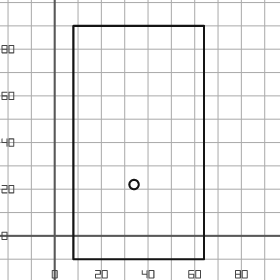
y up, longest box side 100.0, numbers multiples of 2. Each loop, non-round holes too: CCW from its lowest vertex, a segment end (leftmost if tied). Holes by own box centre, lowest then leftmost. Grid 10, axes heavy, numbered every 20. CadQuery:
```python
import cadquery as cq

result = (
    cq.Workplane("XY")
    .moveTo(8.0, -10.0)
    .lineTo(64.0, -10.0)
    .lineTo(64.0, 90.0)
    .lineTo(8.0, 90.0)
    .close()
    .moveTo(34.0, 22.0)
    .circle(2.0)
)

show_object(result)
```